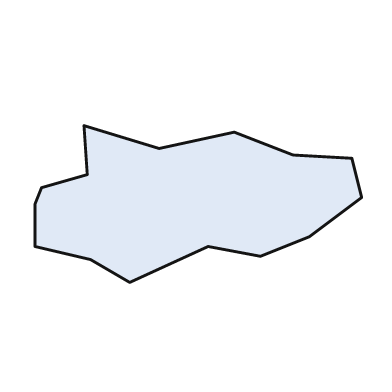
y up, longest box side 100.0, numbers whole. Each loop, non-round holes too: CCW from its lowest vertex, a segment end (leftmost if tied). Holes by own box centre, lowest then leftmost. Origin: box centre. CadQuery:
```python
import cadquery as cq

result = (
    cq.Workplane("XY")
    .moveTo(-21.0, -24.0)
    .lineTo(3.0, -13.0)
    .lineTo(19.0, -16.0)
    .lineTo(34.0, -10.0)
    .lineTo(50.0, 2.0)
    .lineTo(47.0, 14.0)
    .lineTo(29.0, 15.0)
    .lineTo(11.0, 22.0)
    .lineTo(-12.0, 17.0)
    .lineTo(-35.0, 24.0)
    .lineTo(-34.0, 9.0)
    .lineTo(-48.0, 5.0)
    .lineTo(-50.0, 0.0)
    .lineTo(-50.0, -13.0)
    .lineTo(-33.0, -17.0)
    .close()
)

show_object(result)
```